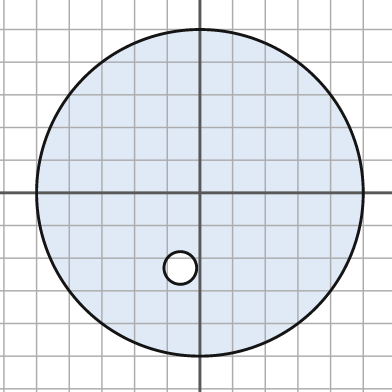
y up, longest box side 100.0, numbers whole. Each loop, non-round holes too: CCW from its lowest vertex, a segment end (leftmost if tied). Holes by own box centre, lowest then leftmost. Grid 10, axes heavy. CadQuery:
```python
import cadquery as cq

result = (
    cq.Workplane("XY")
    .moveTo(0.0, 0.0)
    .circle(50.0)
    .moveTo(-6.0, -23.0)
    .circle(5.0)
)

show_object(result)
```